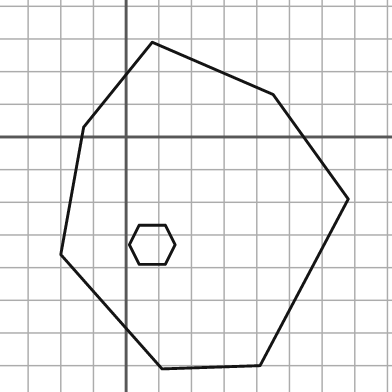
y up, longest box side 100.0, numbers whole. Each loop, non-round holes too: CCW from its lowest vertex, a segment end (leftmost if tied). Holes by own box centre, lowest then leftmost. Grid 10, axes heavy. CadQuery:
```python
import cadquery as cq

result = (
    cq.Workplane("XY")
    .moveTo(11.0, -71.0)
    .lineTo(41.0, -70.0)
    .lineTo(68.0, -19.0)
    .lineTo(45.0, 13.0)
    .lineTo(8.0, 29.0)
    .lineTo(-13.0, 3.0)
    .lineTo(-20.0, -36.0)
    .close()
    .moveTo(4.0, -39.0)
    .lineTo(12.0, -39.0)
    .lineTo(15.0, -33.0)
    .lineTo(12.0, -27.0)
    .lineTo(4.0, -27.0)
    .lineTo(1.0, -33.0)
    .close()
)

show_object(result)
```